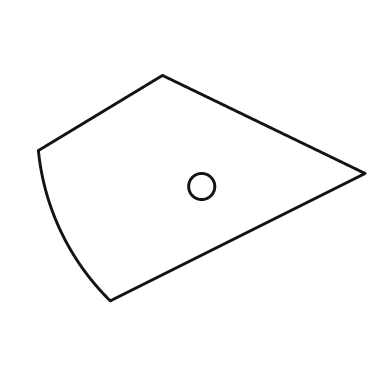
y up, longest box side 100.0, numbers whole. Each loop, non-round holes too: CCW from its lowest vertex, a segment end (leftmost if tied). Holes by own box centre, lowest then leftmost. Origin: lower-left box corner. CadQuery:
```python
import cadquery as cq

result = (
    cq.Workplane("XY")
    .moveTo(22.0, 0.0)
    .lineTo(100.0, 39.0)
    .lineTo(38.0, 69.0)
    .lineTo(0.0, 46.0)
    .threePointArc((7.0, 21.0), (22.0, 0.0))
    .close()
    .moveTo(50.0, 35.0)
    .circle(4.0)
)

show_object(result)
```